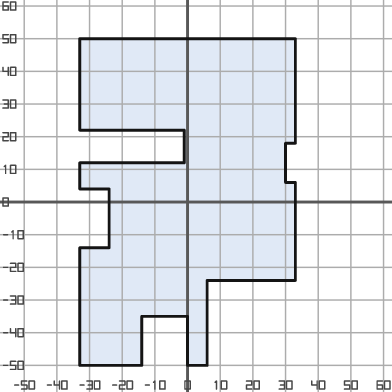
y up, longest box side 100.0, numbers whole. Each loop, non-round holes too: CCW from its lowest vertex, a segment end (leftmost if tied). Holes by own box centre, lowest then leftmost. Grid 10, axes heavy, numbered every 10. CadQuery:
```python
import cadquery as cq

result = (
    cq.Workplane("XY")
    .moveTo(-33.0, -50.0)
    .lineTo(-14.0, -50.0)
    .lineTo(-14.0, -35.0)
    .lineTo(0.0, -35.0)
    .lineTo(0.0, -50.0)
    .lineTo(6.0, -50.0)
    .lineTo(6.0, -24.0)
    .lineTo(33.0, -24.0)
    .lineTo(33.0, 6.0)
    .lineTo(30.0, 6.0)
    .lineTo(30.0, 18.0)
    .lineTo(33.0, 18.0)
    .lineTo(33.0, 50.0)
    .lineTo(-33.0, 50.0)
    .lineTo(-33.0, 22.0)
    .lineTo(-1.0, 22.0)
    .lineTo(-1.0, 12.0)
    .lineTo(-33.0, 12.0)
    .lineTo(-33.0, 4.0)
    .lineTo(-24.0, 4.0)
    .lineTo(-24.0, -14.0)
    .lineTo(-33.0, -14.0)
    .close()
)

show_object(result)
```